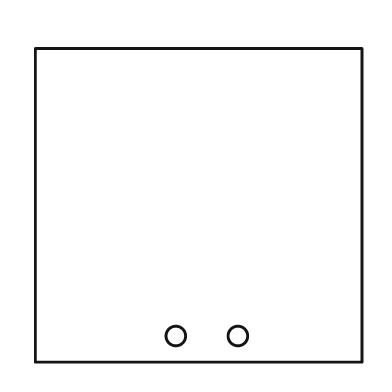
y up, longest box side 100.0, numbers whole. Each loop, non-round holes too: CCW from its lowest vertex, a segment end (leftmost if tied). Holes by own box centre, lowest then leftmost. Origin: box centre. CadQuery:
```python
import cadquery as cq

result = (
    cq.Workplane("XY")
    .moveTo(-50.0, -48.0)
    .lineTo(50.0, -48.0)
    .lineTo(50.0, 48.0)
    .lineTo(-50.0, 48.0)
    .close()
    .moveTo(-7.0, -40.0)
    .circle(3.0)
    .moveTo(12.0, -40.0)
    .circle(3.0)
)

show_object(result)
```